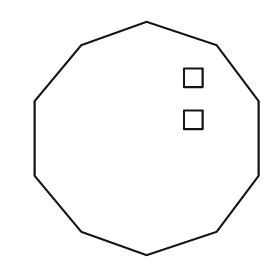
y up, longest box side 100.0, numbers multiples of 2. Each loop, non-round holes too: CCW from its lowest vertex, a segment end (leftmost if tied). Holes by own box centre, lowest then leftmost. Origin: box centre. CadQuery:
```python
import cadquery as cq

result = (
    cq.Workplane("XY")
    .moveTo(0.0, -50.0)
    .lineTo(30.0, -40.0)
    .lineTo(48.0, -16.0)
    .lineTo(48.0, 16.0)
    .lineTo(30.0, 40.0)
    .lineTo(0.0, 50.0)
    .lineTo(-28.0, 40.0)
    .lineTo(-48.0, 16.0)
    .lineTo(-48.0, -16.0)
    .lineTo(-28.0, -40.0)
    .close()
    .moveTo(16.0, 4.0)
    .lineTo(24.0, 4.0)
    .lineTo(24.0, 12.0)
    .lineTo(16.0, 12.0)
    .close()
    .moveTo(16.0, 22.0)
    .lineTo(24.0, 22.0)
    .lineTo(24.0, 30.0)
    .lineTo(16.0, 30.0)
    .close()
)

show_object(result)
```